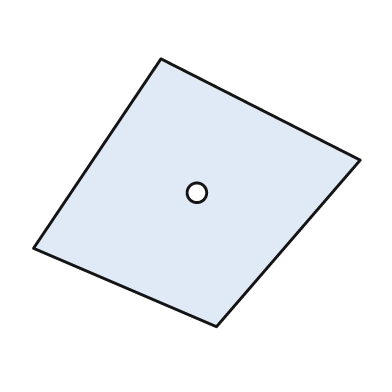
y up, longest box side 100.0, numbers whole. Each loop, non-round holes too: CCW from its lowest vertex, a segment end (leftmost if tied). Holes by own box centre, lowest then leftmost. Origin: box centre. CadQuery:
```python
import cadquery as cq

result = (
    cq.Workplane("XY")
    .moveTo(6.0, -41.0)
    .lineTo(50.0, 10.0)
    .lineTo(-11.0, 41.0)
    .lineTo(-50.0, -17.0)
    .close()
    .moveTo(0.0, 0.0)
    .circle(3.0)
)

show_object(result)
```